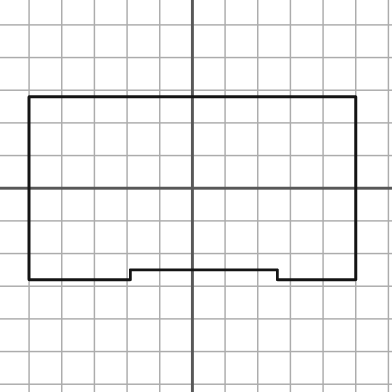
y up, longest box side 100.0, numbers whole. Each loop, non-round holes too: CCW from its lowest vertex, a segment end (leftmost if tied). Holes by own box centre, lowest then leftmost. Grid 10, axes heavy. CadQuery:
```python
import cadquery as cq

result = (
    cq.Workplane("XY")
    .moveTo(-50.0, -28.0)
    .lineTo(-19.0, -28.0)
    .lineTo(-19.0, -25.0)
    .lineTo(26.0, -25.0)
    .lineTo(26.0, -28.0)
    .lineTo(50.0, -28.0)
    .lineTo(50.0, 28.0)
    .lineTo(-50.0, 28.0)
    .close()
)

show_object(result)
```